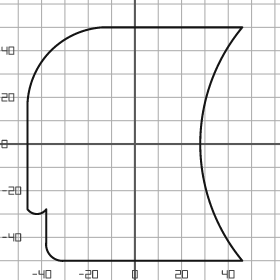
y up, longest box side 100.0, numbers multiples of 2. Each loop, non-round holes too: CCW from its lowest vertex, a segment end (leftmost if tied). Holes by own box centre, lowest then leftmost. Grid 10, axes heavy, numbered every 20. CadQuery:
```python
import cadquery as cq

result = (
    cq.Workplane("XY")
    .moveTo(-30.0, -50.0)
    .lineTo(46.0, -50.0)
    .threePointArc((28.0, 0.0), (46.0, 50.0))
    .lineTo(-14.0, 50.0)
    .threePointArc((-36.0, 40.0), (-46.0, 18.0))
    .lineTo(-46.0, -28.0)
    .threePointArc((-42.0, -30.0), (-38.0, -28.0))
    .lineTo(-38.0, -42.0)
    .threePointArc((-36.0, -48.0), (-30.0, -50.0))
    .close()
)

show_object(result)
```